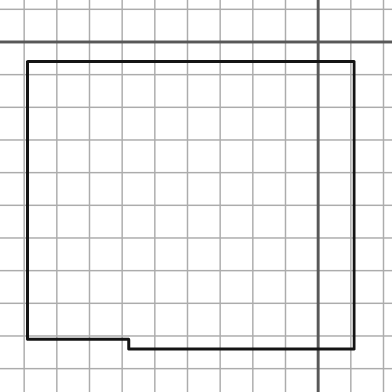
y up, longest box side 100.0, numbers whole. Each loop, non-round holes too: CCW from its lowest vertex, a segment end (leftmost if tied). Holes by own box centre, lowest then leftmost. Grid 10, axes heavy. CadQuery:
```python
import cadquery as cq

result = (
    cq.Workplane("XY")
    .moveTo(-58.0, -94.0)
    .lineTo(11.0, -94.0)
    .lineTo(11.0, -6.0)
    .lineTo(-89.0, -6.0)
    .lineTo(-89.0, -91.0)
    .lineTo(-58.0, -91.0)
    .close()
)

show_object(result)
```